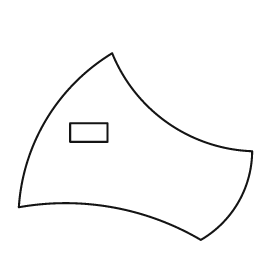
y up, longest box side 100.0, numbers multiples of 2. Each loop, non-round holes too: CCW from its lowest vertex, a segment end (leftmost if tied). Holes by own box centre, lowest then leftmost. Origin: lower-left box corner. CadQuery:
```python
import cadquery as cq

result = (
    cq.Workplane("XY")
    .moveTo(78.0, 0.0)
    .threePointArc((94.0, 16.0), (100.0, 38.0))
    .threePointArc((64.0, 50.0), (40.0, 80.0))
    .threePointArc((12.0, 52.0), (0.0, 14.0))
    .threePointArc((40.0, 14.0), (78.0, 0.0))
    .close()
    .moveTo(22.0, 42.0)
    .lineTo(38.0, 42.0)
    .lineTo(38.0, 50.0)
    .lineTo(22.0, 50.0)
    .close()
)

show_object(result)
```